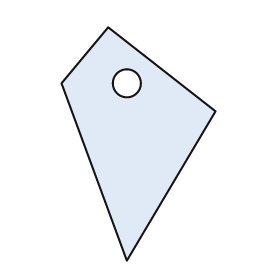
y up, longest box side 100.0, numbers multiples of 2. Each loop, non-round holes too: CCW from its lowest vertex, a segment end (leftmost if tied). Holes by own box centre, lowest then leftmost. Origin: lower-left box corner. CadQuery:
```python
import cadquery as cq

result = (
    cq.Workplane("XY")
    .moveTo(28.0, 0.0)
    .lineTo(66.0, 64.0)
    .lineTo(20.0, 100.0)
    .lineTo(0.0, 76.0)
    .close()
    .moveTo(28.0, 76.0)
    .circle(6.0)
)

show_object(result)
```